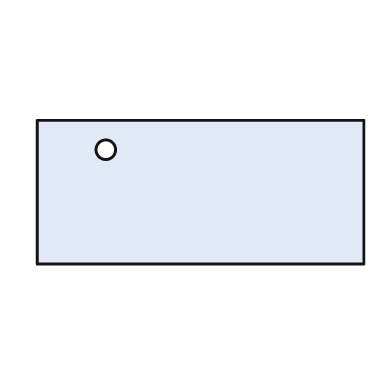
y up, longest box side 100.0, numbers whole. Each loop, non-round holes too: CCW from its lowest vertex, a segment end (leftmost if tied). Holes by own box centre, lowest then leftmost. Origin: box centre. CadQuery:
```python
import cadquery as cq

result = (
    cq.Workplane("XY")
    .moveTo(-50.0, -22.0)
    .lineTo(50.0, -22.0)
    .lineTo(50.0, 22.0)
    .lineTo(-50.0, 22.0)
    .close()
    .moveTo(-29.0, 13.0)
    .circle(3.0)
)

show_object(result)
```